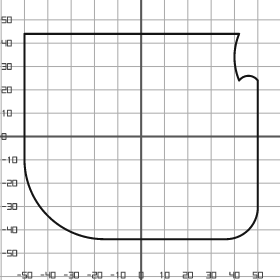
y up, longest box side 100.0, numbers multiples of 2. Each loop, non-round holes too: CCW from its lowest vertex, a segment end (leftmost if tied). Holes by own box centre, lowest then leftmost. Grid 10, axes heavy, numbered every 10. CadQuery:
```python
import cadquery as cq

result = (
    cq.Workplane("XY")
    .moveTo(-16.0, -44.0)
    .lineTo(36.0, -44.0)
    .threePointArc((46.0, -40.0), (50.0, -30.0))
    .lineTo(50.0, 24.0)
    .threePointArc((46.0, 26.0), (42.0, 24.0))
    .threePointArc((40.0, 34.0), (42.0, 44.0))
    .lineTo(-50.0, 44.0)
    .lineTo(-50.0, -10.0)
    .threePointArc((-40.0, -34.0), (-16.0, -44.0))
    .close()
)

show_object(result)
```